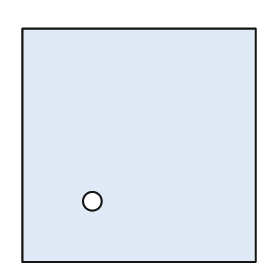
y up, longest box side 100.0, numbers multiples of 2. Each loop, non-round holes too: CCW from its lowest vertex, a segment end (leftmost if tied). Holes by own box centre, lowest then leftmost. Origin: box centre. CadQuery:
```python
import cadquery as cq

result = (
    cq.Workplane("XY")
    .moveTo(-50.0, -50.0)
    .lineTo(50.0, -50.0)
    .lineTo(50.0, 50.0)
    .lineTo(-50.0, 50.0)
    .close()
    .moveTo(-20.0, -24.0)
    .circle(4.0)
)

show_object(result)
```